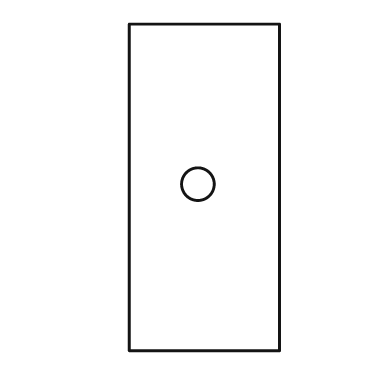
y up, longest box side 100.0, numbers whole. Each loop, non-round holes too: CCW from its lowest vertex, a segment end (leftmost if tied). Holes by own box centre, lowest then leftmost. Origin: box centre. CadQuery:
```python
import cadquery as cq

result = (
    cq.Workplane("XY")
    .moveTo(-23.0, -50.0)
    .lineTo(23.0, -50.0)
    .lineTo(23.0, 50.0)
    .lineTo(-23.0, 50.0)
    .close()
    .moveTo(-2.0, 1.0)
    .circle(5.0)
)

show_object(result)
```